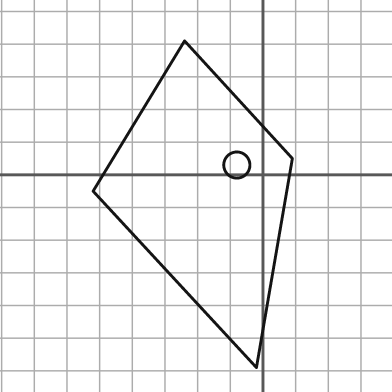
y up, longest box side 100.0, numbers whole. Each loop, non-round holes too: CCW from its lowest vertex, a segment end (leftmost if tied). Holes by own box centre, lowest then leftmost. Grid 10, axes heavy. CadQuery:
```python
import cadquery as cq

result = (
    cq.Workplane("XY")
    .moveTo(-2.0, -59.0)
    .lineTo(9.0, 5.0)
    .lineTo(-24.0, 41.0)
    .lineTo(-52.0, -5.0)
    .close()
    .moveTo(-8.0, 3.0)
    .circle(4.0)
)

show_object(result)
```